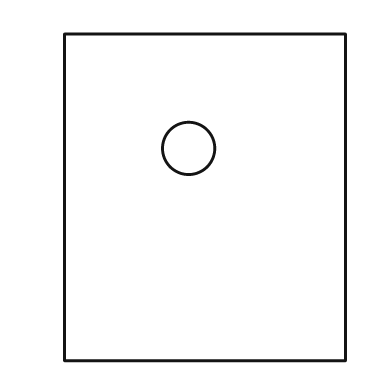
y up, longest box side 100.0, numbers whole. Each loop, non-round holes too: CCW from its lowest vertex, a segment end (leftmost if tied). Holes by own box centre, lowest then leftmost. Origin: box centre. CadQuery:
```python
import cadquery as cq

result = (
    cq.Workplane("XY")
    .moveTo(-43.0, -50.0)
    .lineTo(43.0, -50.0)
    .lineTo(43.0, 50.0)
    .lineTo(-43.0, 50.0)
    .close()
    .moveTo(-5.0, 15.0)
    .circle(8.0)
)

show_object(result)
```